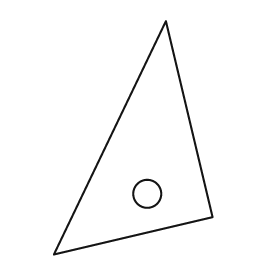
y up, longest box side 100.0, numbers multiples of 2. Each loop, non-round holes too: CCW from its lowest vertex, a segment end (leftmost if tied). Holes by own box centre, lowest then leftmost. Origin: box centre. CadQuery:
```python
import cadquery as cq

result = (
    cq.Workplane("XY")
    .moveTo(-34.0, -50.0)
    .lineTo(34.0, -34.0)
    .lineTo(14.0, 50.0)
    .close()
    .moveTo(6.0, -24.0)
    .circle(6.0)
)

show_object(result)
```